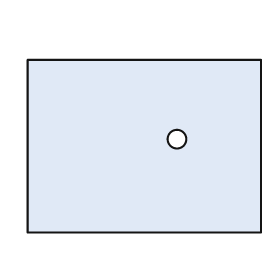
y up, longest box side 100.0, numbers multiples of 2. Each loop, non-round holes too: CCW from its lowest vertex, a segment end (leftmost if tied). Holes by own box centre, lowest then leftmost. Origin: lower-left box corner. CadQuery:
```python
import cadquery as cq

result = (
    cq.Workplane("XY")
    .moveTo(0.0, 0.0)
    .lineTo(100.0, 0.0)
    .lineTo(100.0, 74.0)
    .lineTo(0.0, 74.0)
    .close()
    .moveTo(64.0, 40.0)
    .circle(4.0)
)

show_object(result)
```